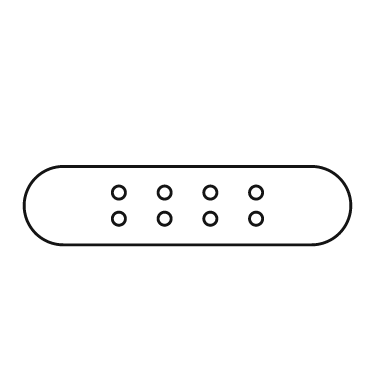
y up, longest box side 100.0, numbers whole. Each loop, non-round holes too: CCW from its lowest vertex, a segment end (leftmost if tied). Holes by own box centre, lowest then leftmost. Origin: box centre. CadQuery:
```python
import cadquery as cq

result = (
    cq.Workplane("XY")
    .moveTo(-38.0, -12.0)
    .lineTo(38.0, -12.0)
    .threePointArc((50.0, 0.0), (38.0, 12.0))
    .lineTo(-38.0, 12.0)
    .threePointArc((-50.0, 0.0), (-38.0, -12.0))
    .close()
    .moveTo(-21.0, -4.0)
    .circle(2.0)
    .moveTo(-7.0, -4.0)
    .circle(2.0)
    .moveTo(7.0, -4.0)
    .circle(2.0)
    .moveTo(21.0, -4.0)
    .circle(2.0)
    .moveTo(-21.0, 4.0)
    .circle(2.0)
    .moveTo(-7.0, 4.0)
    .circle(2.0)
    .moveTo(7.0, 4.0)
    .circle(2.0)
    .moveTo(21.0, 4.0)
    .circle(2.0)
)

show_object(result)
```